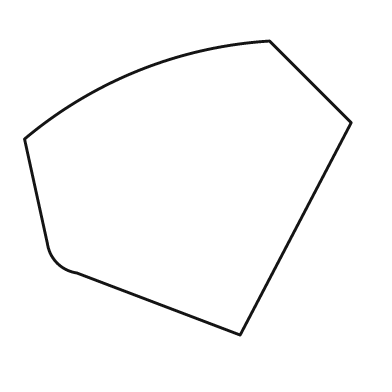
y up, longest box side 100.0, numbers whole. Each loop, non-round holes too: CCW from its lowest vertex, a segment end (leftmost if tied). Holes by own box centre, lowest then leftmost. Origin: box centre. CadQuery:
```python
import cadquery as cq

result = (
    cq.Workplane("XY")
    .moveTo(16.0, -45.0)
    .lineTo(50.0, 20.0)
    .lineTo(25.0, 45.0)
    .threePointArc((-15.0, 36.0), (-50.0, 15.0))
    .lineTo(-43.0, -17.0)
    .threePointArc((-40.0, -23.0), (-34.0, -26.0))
    .close()
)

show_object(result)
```